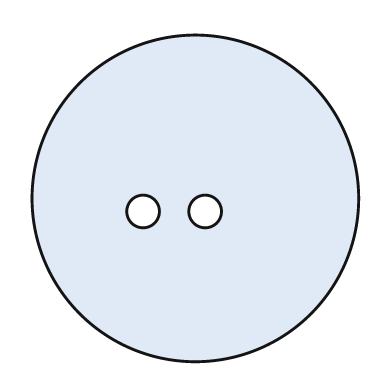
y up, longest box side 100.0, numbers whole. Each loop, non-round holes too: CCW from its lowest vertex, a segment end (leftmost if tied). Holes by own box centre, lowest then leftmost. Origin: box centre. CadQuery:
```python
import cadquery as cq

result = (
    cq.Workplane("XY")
    .moveTo(0.0, 0.0)
    .circle(50.0)
    .moveTo(-16.0, -4.0)
    .circle(5.0)
    .moveTo(3.0, -4.0)
    .circle(5.0)
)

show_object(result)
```